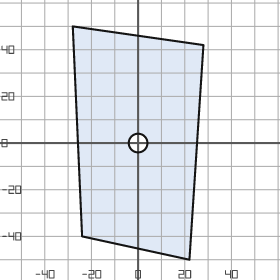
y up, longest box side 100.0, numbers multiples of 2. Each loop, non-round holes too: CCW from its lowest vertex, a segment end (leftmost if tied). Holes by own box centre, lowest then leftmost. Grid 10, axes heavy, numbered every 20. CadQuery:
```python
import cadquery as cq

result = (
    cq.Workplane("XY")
    .moveTo(22.0, -50.0)
    .lineTo(28.0, 42.0)
    .lineTo(-28.0, 50.0)
    .lineTo(-24.0, -40.0)
    .close()
    .moveTo(0.0, 0.0)
    .circle(4.0)
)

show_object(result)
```